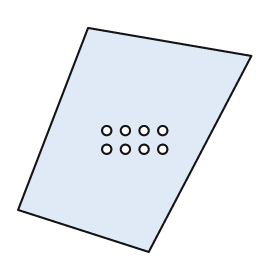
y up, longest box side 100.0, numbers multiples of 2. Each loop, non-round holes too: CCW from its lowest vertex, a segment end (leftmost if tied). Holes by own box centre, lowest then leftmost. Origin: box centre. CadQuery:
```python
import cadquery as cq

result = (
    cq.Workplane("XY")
    .moveTo(6.0, -48.0)
    .lineTo(50.0, 36.0)
    .lineTo(-20.0, 48.0)
    .lineTo(-50.0, -30.0)
    .close()
    .moveTo(-12.0, -4.0)
    .circle(2.0)
    .moveTo(-4.0, -4.0)
    .circle(2.0)
    .moveTo(4.0, -4.0)
    .circle(2.0)
    .moveTo(12.0, -4.0)
    .circle(2.0)
    .moveTo(-12.0, 4.0)
    .circle(2.0)
    .moveTo(-4.0, 4.0)
    .circle(2.0)
    .moveTo(4.0, 4.0)
    .circle(2.0)
    .moveTo(12.0, 4.0)
    .circle(2.0)
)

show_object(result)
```